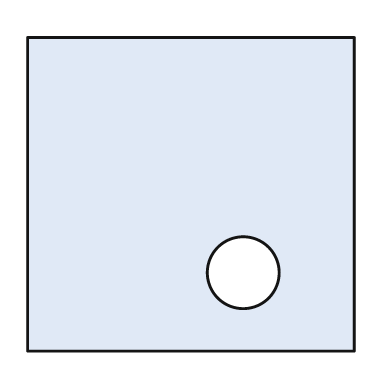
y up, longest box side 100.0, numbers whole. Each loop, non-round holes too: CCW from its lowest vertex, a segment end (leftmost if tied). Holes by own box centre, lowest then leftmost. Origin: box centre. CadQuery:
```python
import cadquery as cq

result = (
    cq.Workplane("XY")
    .moveTo(-50.0, -48.0)
    .lineTo(50.0, -48.0)
    .lineTo(50.0, 48.0)
    .lineTo(-50.0, 48.0)
    .close()
    .moveTo(16.0, -24.0)
    .circle(11.0)
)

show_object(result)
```